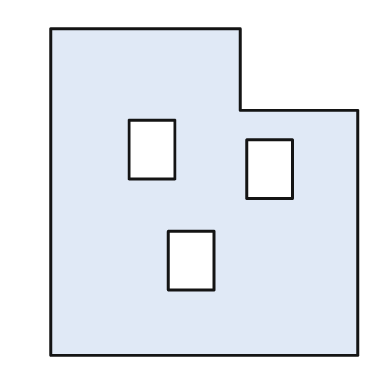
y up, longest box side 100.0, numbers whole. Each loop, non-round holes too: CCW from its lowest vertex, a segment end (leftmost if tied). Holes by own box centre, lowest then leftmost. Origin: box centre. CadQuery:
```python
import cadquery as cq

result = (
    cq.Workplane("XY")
    .moveTo(-47.0, -50.0)
    .lineTo(47.0, -50.0)
    .lineTo(47.0, 25.0)
    .lineTo(11.0, 25.0)
    .lineTo(11.0, 50.0)
    .lineTo(-47.0, 50.0)
    .close()
    .moveTo(-11.0, -30.0)
    .lineTo(3.0, -30.0)
    .lineTo(3.0, -12.0)
    .lineTo(-11.0, -12.0)
    .close()
    .moveTo(13.0, -2.0)
    .lineTo(27.0, -2.0)
    .lineTo(27.0, 16.0)
    .lineTo(13.0, 16.0)
    .close()
    .moveTo(-23.0, 4.0)
    .lineTo(-9.0, 4.0)
    .lineTo(-9.0, 22.0)
    .lineTo(-23.0, 22.0)
    .close()
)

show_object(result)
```